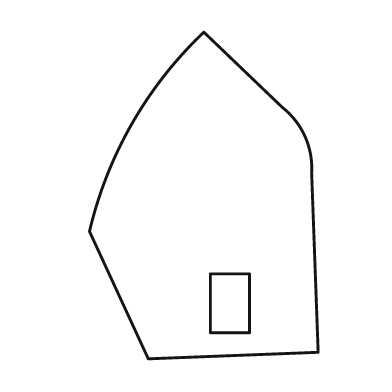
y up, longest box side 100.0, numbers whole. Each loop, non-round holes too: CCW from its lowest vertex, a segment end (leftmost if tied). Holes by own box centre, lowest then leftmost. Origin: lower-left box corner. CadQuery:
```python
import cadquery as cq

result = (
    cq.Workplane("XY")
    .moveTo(18.0, 0.0)
    .lineTo(70.0, 2.0)
    .lineTo(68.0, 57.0)
    .threePointArc((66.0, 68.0), (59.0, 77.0))
    .lineTo(35.0, 100.0)
    .threePointArc((13.0, 72.0), (0.0, 39.0))
    .close()
    .moveTo(37.0, 8.0)
    .lineTo(49.0, 8.0)
    .lineTo(49.0, 26.0)
    .lineTo(37.0, 26.0)
    .close()
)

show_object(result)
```